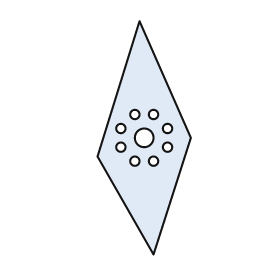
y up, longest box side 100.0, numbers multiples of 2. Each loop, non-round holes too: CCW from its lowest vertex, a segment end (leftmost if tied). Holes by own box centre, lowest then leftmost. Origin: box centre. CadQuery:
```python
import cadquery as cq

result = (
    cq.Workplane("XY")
    .moveTo(4.0, -50.0)
    .lineTo(20.0, 0.0)
    .lineTo(-2.0, 50.0)
    .lineTo(-20.0, -8.0)
    .close()
    .moveTo(-4.0, -10.0)
    .circle(2.0)
    .moveTo(4.0, -10.0)
    .circle(2.0)
    .moveTo(-10.0, -4.0)
    .circle(2.0)
    .moveTo(10.0, -4.0)
    .circle(2.0)
    .moveTo(0.0, 0.0)
    .circle(4.0)
    .moveTo(-10.0, 4.0)
    .circle(2.0)
    .moveTo(10.0, 4.0)
    .circle(2.0)
    .moveTo(-4.0, 10.0)
    .circle(2.0)
    .moveTo(4.0, 10.0)
    .circle(2.0)
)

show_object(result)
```